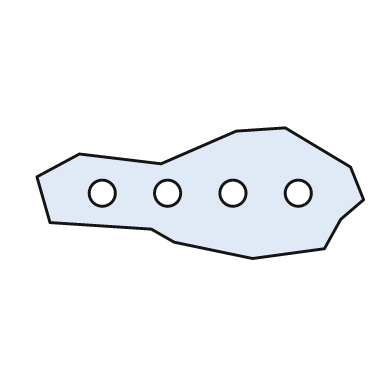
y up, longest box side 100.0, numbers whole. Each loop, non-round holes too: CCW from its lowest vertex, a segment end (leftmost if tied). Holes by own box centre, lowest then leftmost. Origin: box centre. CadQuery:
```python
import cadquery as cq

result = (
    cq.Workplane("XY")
    .moveTo(16.0, -20.0)
    .lineTo(38.0, -17.0)
    .lineTo(43.0, -8.0)
    .lineTo(50.0, -2.0)
    .lineTo(46.0, 8.0)
    .lineTo(26.0, 20.0)
    .lineTo(11.0, 19.0)
    .lineTo(-12.0, 9.0)
    .lineTo(-37.0, 12.0)
    .lineTo(-50.0, 5.0)
    .lineTo(-46.0, -9.0)
    .lineTo(-15.0, -11.0)
    .lineTo(-8.0, -15.0)
    .close()
    .moveTo(-30.0, 0.0)
    .circle(4.0)
    .moveTo(-10.0, 0.0)
    .circle(4.0)
    .moveTo(10.0, 0.0)
    .circle(4.0)
    .moveTo(30.0, 0.0)
    .circle(4.0)
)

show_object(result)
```